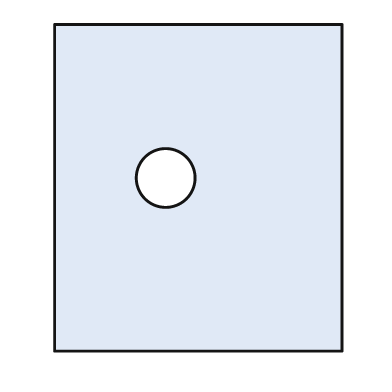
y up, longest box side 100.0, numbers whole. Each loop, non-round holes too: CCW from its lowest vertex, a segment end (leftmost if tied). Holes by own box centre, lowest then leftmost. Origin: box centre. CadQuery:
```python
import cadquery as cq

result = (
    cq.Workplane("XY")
    .moveTo(-44.0, -50.0)
    .lineTo(44.0, -50.0)
    .lineTo(44.0, 50.0)
    .lineTo(-44.0, 50.0)
    .close()
    .moveTo(-10.0, 3.0)
    .circle(9.0)
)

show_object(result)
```